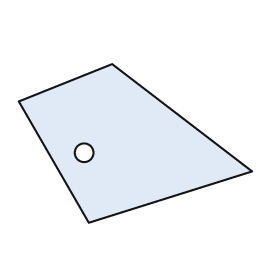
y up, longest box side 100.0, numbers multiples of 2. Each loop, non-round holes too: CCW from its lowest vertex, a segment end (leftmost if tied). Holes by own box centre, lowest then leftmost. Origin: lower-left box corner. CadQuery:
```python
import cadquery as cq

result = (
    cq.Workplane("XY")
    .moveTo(30.0, 0.0)
    .lineTo(100.0, 22.0)
    .lineTo(40.0, 68.0)
    .lineTo(0.0, 52.0)
    .close()
    .moveTo(28.0, 30.0)
    .circle(4.0)
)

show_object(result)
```